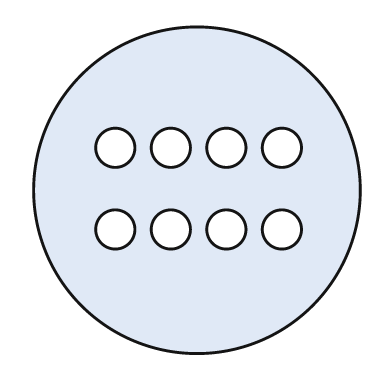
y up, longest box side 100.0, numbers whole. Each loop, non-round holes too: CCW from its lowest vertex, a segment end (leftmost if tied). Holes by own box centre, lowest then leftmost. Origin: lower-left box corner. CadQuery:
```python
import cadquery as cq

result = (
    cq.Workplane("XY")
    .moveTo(50.0, 50.0)
    .circle(50.0)
    .moveTo(25.0, 38.0)
    .circle(6.0)
    .moveTo(42.0, 38.0)
    .circle(6.0)
    .moveTo(59.0, 38.0)
    .circle(6.0)
    .moveTo(76.0, 38.0)
    .circle(6.0)
    .moveTo(25.0, 63.0)
    .circle(6.0)
    .moveTo(42.0, 63.0)
    .circle(6.0)
    .moveTo(59.0, 63.0)
    .circle(6.0)
    .moveTo(76.0, 63.0)
    .circle(6.0)
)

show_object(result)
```